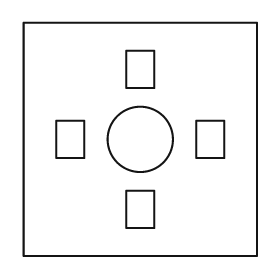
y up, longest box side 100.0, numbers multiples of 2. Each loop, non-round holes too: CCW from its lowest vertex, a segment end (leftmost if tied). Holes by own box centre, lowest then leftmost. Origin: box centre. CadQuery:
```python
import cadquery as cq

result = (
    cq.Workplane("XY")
    .moveTo(-50.0, -50.0)
    .lineTo(50.0, -50.0)
    .lineTo(50.0, 50.0)
    .lineTo(-50.0, 50.0)
    .close()
    .moveTo(-6.0, -38.0)
    .lineTo(6.0, -38.0)
    .lineTo(6.0, -22.0)
    .lineTo(-6.0, -22.0)
    .close()
    .moveTo(-36.0, -8.0)
    .lineTo(-24.0, -8.0)
    .lineTo(-24.0, 8.0)
    .lineTo(-36.0, 8.0)
    .close()
    .moveTo(0.0, 0.0)
    .circle(14.0)
    .moveTo(24.0, -8.0)
    .lineTo(36.0, -8.0)
    .lineTo(36.0, 8.0)
    .lineTo(24.0, 8.0)
    .close()
    .moveTo(-6.0, 22.0)
    .lineTo(6.0, 22.0)
    .lineTo(6.0, 38.0)
    .lineTo(-6.0, 38.0)
    .close()
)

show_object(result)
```